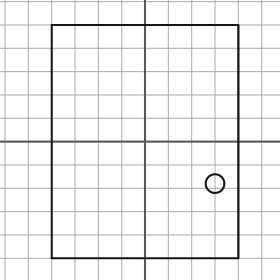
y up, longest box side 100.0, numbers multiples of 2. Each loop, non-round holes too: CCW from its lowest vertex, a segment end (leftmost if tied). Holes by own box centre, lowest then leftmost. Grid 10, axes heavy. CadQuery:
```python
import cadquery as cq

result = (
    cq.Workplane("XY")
    .moveTo(-40.0, -50.0)
    .lineTo(40.0, -50.0)
    .lineTo(40.0, 50.0)
    .lineTo(-40.0, 50.0)
    .close()
    .moveTo(30.0, -18.0)
    .circle(4.0)
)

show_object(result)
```